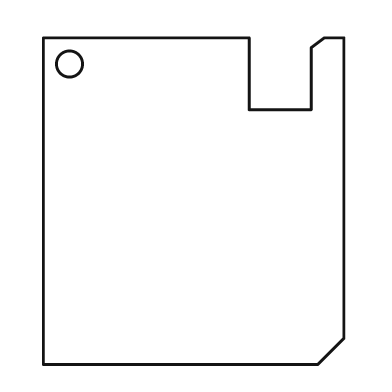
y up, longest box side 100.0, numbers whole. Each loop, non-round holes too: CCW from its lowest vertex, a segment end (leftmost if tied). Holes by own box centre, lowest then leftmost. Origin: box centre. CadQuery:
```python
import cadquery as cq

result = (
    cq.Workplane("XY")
    .moveTo(-46.0, -50.0)
    .lineTo(38.0, -50.0)
    .lineTo(46.0, -42.0)
    .lineTo(46.0, 50.0)
    .lineTo(40.0, 50.0)
    .lineTo(36.0, 47.0)
    .lineTo(36.0, 28.0)
    .lineTo(17.0, 28.0)
    .lineTo(17.0, 50.0)
    .lineTo(-46.0, 50.0)
    .close()
    .moveTo(-38.0, 42.0)
    .circle(4.0)
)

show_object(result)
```